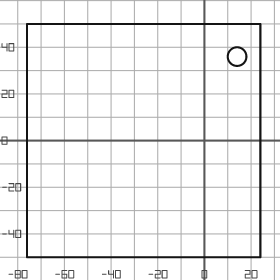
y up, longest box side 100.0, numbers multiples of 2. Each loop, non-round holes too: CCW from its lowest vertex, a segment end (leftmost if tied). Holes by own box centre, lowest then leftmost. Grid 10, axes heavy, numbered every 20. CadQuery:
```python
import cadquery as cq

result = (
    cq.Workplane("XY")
    .moveTo(-76.0, -50.0)
    .lineTo(24.0, -50.0)
    .lineTo(24.0, 50.0)
    .lineTo(-76.0, 50.0)
    .close()
    .moveTo(14.0, 36.0)
    .circle(4.0)
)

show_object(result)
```